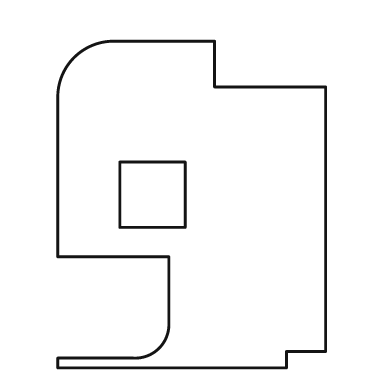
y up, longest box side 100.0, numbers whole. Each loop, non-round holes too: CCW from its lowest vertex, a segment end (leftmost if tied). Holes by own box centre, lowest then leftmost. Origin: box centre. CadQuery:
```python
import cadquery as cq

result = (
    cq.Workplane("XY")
    .moveTo(-41.0, -50.0)
    .lineTo(29.0, -50.0)
    .lineTo(29.0, -45.0)
    .lineTo(41.0, -45.0)
    .lineTo(41.0, 36.0)
    .lineTo(7.0, 36.0)
    .lineTo(7.0, 50.0)
    .lineTo(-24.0, 50.0)
    .threePointArc((-36.0, 45.0), (-41.0, 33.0))
    .lineTo(-41.0, -16.0)
    .lineTo(-7.0, -16.0)
    .lineTo(-7.0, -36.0)
    .threePointArc((-10.0, -44.0), (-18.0, -47.0))
    .lineTo(-41.0, -47.0)
    .close()
    .moveTo(-22.0, -7.0)
    .lineTo(-2.0, -7.0)
    .lineTo(-2.0, 13.0)
    .lineTo(-22.0, 13.0)
    .close()
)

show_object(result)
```